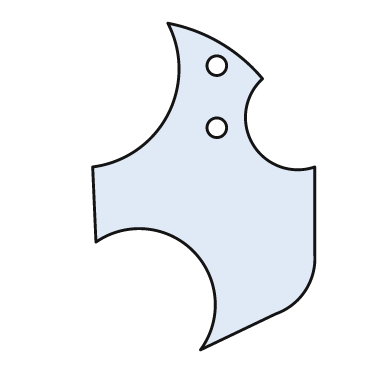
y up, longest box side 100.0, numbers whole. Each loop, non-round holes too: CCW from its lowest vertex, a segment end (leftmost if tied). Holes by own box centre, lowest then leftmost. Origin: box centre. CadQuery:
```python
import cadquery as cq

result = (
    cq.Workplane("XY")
    .moveTo(-1.0, -50.0)
    .lineTo(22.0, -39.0)
    .threePointArc((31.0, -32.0), (34.0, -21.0))
    .lineTo(34.0, 6.0)
    .threePointArc((15.0, 13.0), (18.0, 33.0))
    .threePointArc((5.0, 44.0), (-11.0, 50.0))
    .threePointArc((-11.0, 22.0), (-34.0, 6.0))
    .lineTo(-33.0, -17.0)
    .threePointArc((-3.0, -20.0), (-1.0, -50.0))
    .close()
    .moveTo(4.0, 18.0)
    .circle(3.0)
    .moveTo(4.0, 37.0)
    .circle(3.0)
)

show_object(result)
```